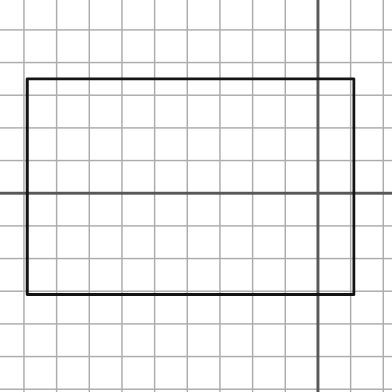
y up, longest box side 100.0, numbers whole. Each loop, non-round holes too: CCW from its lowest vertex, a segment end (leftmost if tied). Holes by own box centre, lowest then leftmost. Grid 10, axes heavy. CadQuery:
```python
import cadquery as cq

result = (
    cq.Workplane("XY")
    .moveTo(-89.0, -31.0)
    .lineTo(11.0, -31.0)
    .lineTo(11.0, 35.0)
    .lineTo(-89.0, 35.0)
    .close()
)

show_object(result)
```